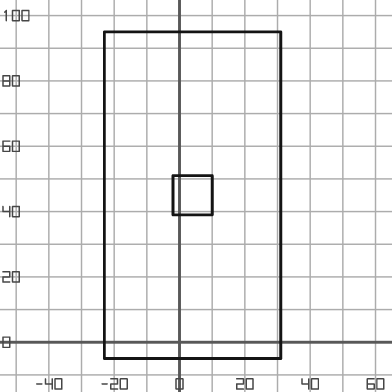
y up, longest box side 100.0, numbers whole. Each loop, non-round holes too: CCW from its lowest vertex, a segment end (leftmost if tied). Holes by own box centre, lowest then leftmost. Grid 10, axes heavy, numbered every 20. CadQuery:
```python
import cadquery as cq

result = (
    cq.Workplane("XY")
    .moveTo(-23.0, -5.0)
    .lineTo(31.0, -5.0)
    .lineTo(31.0, 95.0)
    .lineTo(-23.0, 95.0)
    .close()
    .moveTo(-2.0, 39.0)
    .lineTo(10.0, 39.0)
    .lineTo(10.0, 51.0)
    .lineTo(-2.0, 51.0)
    .close()
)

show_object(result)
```